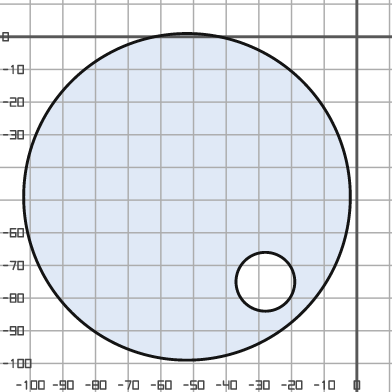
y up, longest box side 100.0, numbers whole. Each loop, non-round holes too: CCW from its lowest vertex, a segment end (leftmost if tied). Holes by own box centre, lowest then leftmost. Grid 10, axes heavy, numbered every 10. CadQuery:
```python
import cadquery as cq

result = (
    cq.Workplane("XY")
    .moveTo(-52.0, -49.0)
    .circle(50.0)
    .moveTo(-28.0, -75.0)
    .circle(9.0)
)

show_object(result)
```